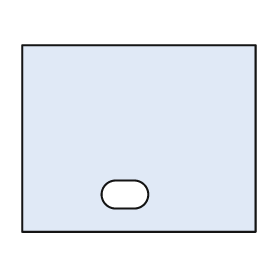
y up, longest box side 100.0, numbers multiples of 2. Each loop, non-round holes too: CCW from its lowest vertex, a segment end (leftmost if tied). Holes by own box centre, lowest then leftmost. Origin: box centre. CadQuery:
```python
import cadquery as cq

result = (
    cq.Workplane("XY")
    .moveTo(-50.0, -40.0)
    .lineTo(50.0, -40.0)
    .lineTo(50.0, 40.0)
    .lineTo(-50.0, 40.0)
    .close()
    .moveTo(-10.0, -30.0)
    .lineTo(-2.0, -30.0)
    .threePointArc((4.0, -24.0), (-2.0, -18.0))
    .lineTo(-10.0, -18.0)
    .threePointArc((-16.0, -24.0), (-10.0, -30.0))
    .close()
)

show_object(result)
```